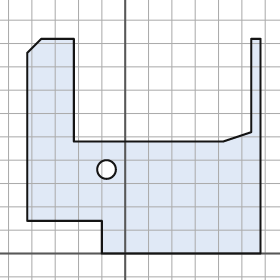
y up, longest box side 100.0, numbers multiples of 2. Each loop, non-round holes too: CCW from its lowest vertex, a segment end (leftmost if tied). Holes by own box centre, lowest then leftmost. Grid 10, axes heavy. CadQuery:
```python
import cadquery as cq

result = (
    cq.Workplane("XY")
    .moveTo(-10.0, 0.0)
    .lineTo(58.0, 0.0)
    .lineTo(58.0, 92.0)
    .lineTo(54.0, 92.0)
    .lineTo(54.0, 52.0)
    .lineTo(42.0, 48.0)
    .lineTo(-22.0, 48.0)
    .lineTo(-22.0, 92.0)
    .lineTo(-36.0, 92.0)
    .lineTo(-42.0, 86.0)
    .lineTo(-42.0, 14.0)
    .lineTo(-10.0, 14.0)
    .close()
    .moveTo(-8.0, 36.0)
    .circle(4.0)
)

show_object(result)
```